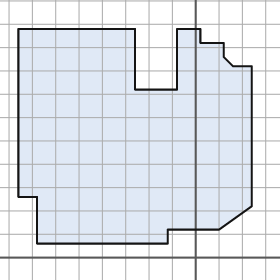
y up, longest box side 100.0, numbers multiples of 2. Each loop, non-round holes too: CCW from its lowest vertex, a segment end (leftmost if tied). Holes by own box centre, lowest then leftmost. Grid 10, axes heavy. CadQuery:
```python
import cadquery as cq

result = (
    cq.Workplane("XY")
    .moveTo(-68.0, 6.0)
    .lineTo(-12.0, 6.0)
    .lineTo(-12.0, 12.0)
    .lineTo(10.0, 12.0)
    .lineTo(24.0, 22.0)
    .lineTo(24.0, 82.0)
    .lineTo(16.0, 82.0)
    .lineTo(12.0, 86.0)
    .lineTo(12.0, 92.0)
    .lineTo(2.0, 92.0)
    .lineTo(2.0, 98.0)
    .lineTo(-8.0, 98.0)
    .lineTo(-8.0, 72.0)
    .lineTo(-26.0, 72.0)
    .lineTo(-26.0, 98.0)
    .lineTo(-76.0, 98.0)
    .lineTo(-76.0, 26.0)
    .lineTo(-68.0, 26.0)
    .close()
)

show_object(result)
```